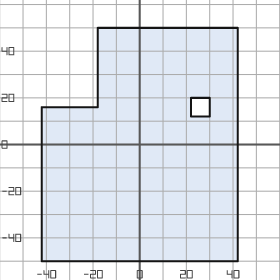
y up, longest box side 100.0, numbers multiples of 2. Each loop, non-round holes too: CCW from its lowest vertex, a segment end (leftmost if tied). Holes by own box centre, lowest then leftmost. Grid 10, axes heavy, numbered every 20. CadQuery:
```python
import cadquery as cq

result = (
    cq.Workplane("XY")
    .moveTo(-42.0, -50.0)
    .lineTo(42.0, -50.0)
    .lineTo(42.0, 50.0)
    .lineTo(-18.0, 50.0)
    .lineTo(-18.0, 16.0)
    .lineTo(-42.0, 16.0)
    .close()
    .moveTo(22.0, 12.0)
    .lineTo(30.0, 12.0)
    .lineTo(30.0, 20.0)
    .lineTo(22.0, 20.0)
    .close()
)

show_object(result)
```